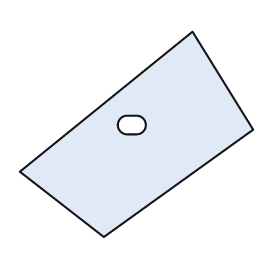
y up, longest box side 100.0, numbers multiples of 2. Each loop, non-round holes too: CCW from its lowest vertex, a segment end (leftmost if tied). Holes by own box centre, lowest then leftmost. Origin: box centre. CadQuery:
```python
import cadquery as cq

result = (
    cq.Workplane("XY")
    .moveTo(-14.0, -44.0)
    .lineTo(50.0, 2.0)
    .lineTo(24.0, 44.0)
    .lineTo(-50.0, -16.0)
    .close()
    .moveTo(-4.0, 0.0)
    .lineTo(0.0, 0.0)
    .threePointArc((4.0, 4.0), (0.0, 8.0))
    .lineTo(-4.0, 8.0)
    .threePointArc((-8.0, 4.0), (-4.0, 0.0))
    .close()
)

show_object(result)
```